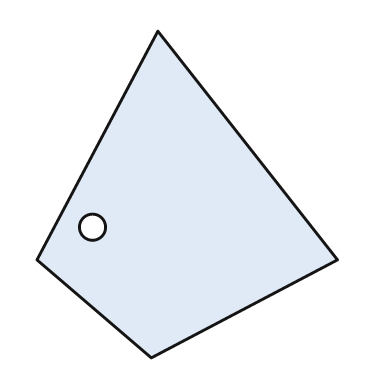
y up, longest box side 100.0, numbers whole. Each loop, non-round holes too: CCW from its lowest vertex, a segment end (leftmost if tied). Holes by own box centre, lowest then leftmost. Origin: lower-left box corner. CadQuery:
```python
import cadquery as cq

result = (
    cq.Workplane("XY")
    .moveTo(35.0, 0.0)
    .lineTo(92.0, 30.0)
    .lineTo(37.0, 100.0)
    .lineTo(0.0, 30.0)
    .close()
    .moveTo(17.0, 40.0)
    .circle(4.0)
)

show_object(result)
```